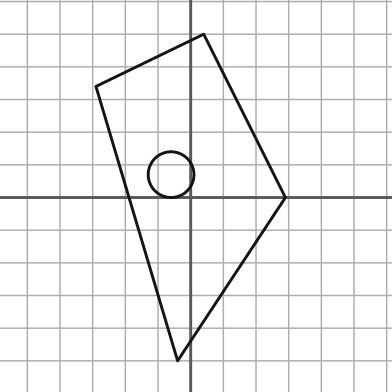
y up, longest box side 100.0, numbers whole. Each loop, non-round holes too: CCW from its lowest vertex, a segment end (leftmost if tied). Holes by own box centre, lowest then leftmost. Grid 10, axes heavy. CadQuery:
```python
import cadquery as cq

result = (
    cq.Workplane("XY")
    .moveTo(-4.0, -50.0)
    .lineTo(29.0, 0.0)
    .lineTo(4.0, 50.0)
    .lineTo(-29.0, 34.0)
    .close()
    .moveTo(-6.0, 7.0)
    .circle(7.0)
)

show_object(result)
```